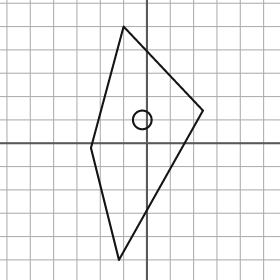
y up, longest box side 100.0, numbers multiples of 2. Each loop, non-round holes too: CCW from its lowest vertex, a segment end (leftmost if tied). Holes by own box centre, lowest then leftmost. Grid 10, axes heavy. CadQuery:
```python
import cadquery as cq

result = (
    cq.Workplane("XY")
    .moveTo(-12.0, -50.0)
    .lineTo(24.0, 14.0)
    .lineTo(-10.0, 50.0)
    .lineTo(-24.0, -2.0)
    .close()
    .moveTo(-2.0, 10.0)
    .circle(4.0)
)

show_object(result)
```